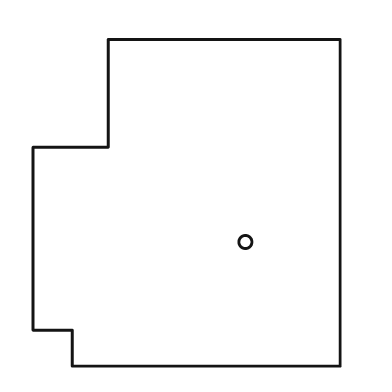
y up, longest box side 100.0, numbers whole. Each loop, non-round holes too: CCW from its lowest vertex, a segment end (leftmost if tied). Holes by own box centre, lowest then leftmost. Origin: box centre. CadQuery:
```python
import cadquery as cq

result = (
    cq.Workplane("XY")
    .moveTo(-35.0, -50.0)
    .lineTo(47.0, -50.0)
    .lineTo(47.0, 50.0)
    .lineTo(-24.0, 50.0)
    .lineTo(-24.0, 17.0)
    .lineTo(-47.0, 17.0)
    .lineTo(-47.0, -39.0)
    .lineTo(-35.0, -39.0)
    .close()
    .moveTo(18.0, -12.0)
    .circle(2.0)
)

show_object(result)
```